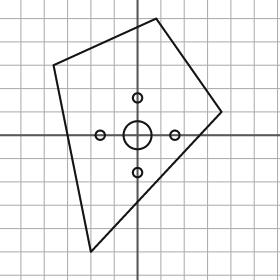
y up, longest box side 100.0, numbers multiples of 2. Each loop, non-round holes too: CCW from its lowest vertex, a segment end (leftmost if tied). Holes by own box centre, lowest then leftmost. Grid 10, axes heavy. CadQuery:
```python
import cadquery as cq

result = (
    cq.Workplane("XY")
    .moveTo(-20.0, -50.0)
    .lineTo(36.0, 10.0)
    .lineTo(8.0, 50.0)
    .lineTo(-36.0, 30.0)
    .close()
    .moveTo(0.0, -16.0)
    .circle(2.0)
    .moveTo(-16.0, 0.0)
    .circle(2.0)
    .moveTo(0.0, 0.0)
    .circle(6.0)
    .moveTo(16.0, 0.0)
    .circle(2.0)
    .moveTo(0.0, 16.0)
    .circle(2.0)
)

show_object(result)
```